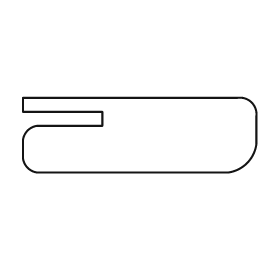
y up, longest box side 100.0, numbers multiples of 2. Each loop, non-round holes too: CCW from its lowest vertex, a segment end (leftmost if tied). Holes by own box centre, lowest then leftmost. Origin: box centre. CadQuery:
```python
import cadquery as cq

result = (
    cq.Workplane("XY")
    .moveTo(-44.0, -16.0)
    .lineTo(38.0, -16.0)
    .threePointArc((46.0, -12.0), (50.0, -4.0))
    .lineTo(50.0, 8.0)
    .threePointArc((48.0, 14.0), (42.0, 16.0))
    .lineTo(-50.0, 16.0)
    .lineTo(-50.0, 10.0)
    .lineTo(-16.0, 10.0)
    .lineTo(-16.0, 4.0)
    .lineTo(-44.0, 4.0)
    .threePointArc((-48.0, 2.0), (-50.0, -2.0))
    .lineTo(-50.0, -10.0)
    .threePointArc((-48.0, -14.0), (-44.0, -16.0))
    .close()
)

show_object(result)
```